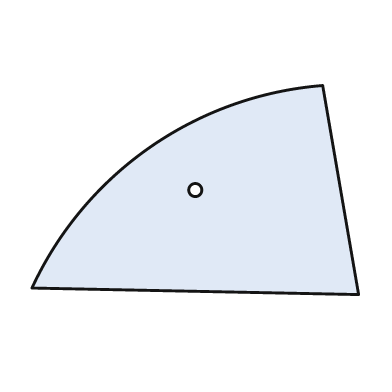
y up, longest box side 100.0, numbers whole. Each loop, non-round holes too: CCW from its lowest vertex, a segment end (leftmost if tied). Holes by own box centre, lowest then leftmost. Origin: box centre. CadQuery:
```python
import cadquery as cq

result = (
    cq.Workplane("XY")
    .moveTo(50.0, -32.0)
    .lineTo(39.0, 32.0)
    .threePointArc((-14.0, 13.0), (-50.0, -30.0))
    .close()
    .moveTo(0.0, 0.0)
    .circle(2.0)
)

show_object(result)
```